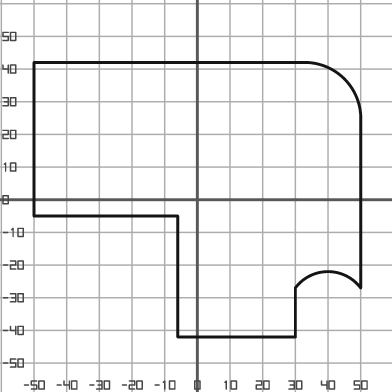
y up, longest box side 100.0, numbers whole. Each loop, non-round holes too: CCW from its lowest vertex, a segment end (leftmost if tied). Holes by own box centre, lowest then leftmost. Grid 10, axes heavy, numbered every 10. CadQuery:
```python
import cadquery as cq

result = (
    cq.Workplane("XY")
    .moveTo(-6.0, -42.0)
    .lineTo(30.0, -42.0)
    .lineTo(30.0, -27.0)
    .threePointArc((40.0, -22.0), (50.0, -27.0))
    .lineTo(50.0, 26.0)
    .threePointArc((45.0, 37.0), (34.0, 42.0))
    .lineTo(-50.0, 42.0)
    .lineTo(-50.0, -5.0)
    .lineTo(-6.0, -5.0)
    .close()
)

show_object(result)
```